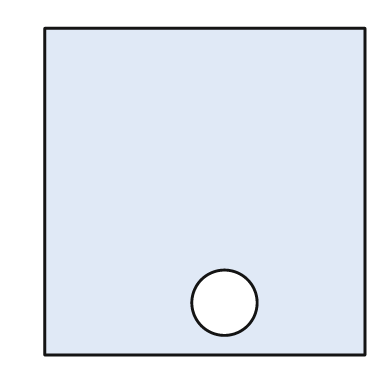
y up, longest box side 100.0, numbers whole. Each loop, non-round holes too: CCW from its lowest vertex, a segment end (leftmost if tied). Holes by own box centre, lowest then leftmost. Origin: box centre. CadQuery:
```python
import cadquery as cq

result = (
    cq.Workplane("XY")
    .moveTo(-49.0, -50.0)
    .lineTo(49.0, -50.0)
    .lineTo(49.0, 50.0)
    .lineTo(-49.0, 50.0)
    .close()
    .moveTo(6.0, -34.0)
    .circle(10.0)
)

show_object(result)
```